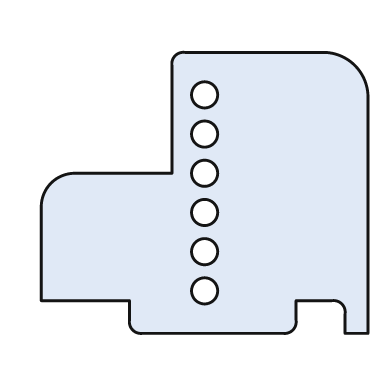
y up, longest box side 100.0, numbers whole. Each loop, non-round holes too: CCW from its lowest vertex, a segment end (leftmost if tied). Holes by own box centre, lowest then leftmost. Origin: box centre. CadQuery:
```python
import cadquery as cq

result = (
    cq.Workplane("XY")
    .moveTo(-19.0, -43.0)
    .lineTo(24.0, -43.0)
    .threePointArc((27.0, -42.0), (28.0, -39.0))
    .lineTo(28.0, -33.0)
    .lineTo(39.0, -33.0)
    .threePointArc((42.0, -34.0), (43.0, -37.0))
    .lineTo(43.0, -43.0)
    .lineTo(50.0, -43.0)
    .lineTo(50.0, 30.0)
    .threePointArc((46.0, 39.0), (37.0, 43.0))
    .lineTo(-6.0, 43.0)
    .threePointArc((-9.0, 42.0), (-10.0, 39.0))
    .lineTo(-10.0, 6.0)
    .lineTo(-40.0, 6.0)
    .threePointArc((-47.0, 3.0), (-50.0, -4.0))
    .lineTo(-50.0, -33.0)
    .lineTo(-23.0, -33.0)
    .lineTo(-23.0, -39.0)
    .threePointArc((-22.0, -42.0), (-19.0, -43.0))
    .close()
    .moveTo(0.0, -30.0)
    .circle(4.0)
    .moveTo(0.0, -18.0)
    .circle(4.0)
    .moveTo(0.0, -6.0)
    .circle(4.0)
    .moveTo(0.0, 6.0)
    .circle(4.0)
    .moveTo(0.0, 18.0)
    .circle(4.0)
    .moveTo(0.0, 30.0)
    .circle(4.0)
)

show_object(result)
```